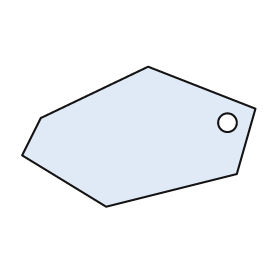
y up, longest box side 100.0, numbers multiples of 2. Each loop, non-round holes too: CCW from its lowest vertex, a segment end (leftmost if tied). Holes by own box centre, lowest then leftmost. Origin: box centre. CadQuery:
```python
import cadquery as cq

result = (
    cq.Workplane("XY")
    .moveTo(-14.0, -30.0)
    .lineTo(42.0, -16.0)
    .lineTo(50.0, 12.0)
    .lineTo(4.0, 30.0)
    .lineTo(-42.0, 8.0)
    .lineTo(-50.0, -8.0)
    .close()
    .moveTo(38.0, 6.0)
    .circle(4.0)
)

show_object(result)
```